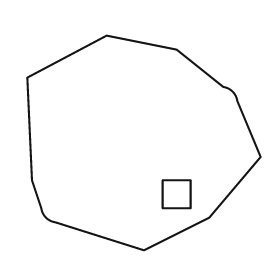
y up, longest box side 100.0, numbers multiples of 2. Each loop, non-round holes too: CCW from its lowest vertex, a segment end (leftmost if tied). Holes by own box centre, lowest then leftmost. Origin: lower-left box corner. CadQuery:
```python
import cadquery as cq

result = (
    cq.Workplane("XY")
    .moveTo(50.0, 0.0)
    .lineTo(78.0, 14.0)
    .lineTo(100.0, 40.0)
    .lineTo(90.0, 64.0)
    .threePointArc((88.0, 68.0), (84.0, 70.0))
    .lineTo(64.0, 86.0)
    .lineTo(34.0, 92.0)
    .lineTo(0.0, 74.0)
    .lineTo(2.0, 30.0)
    .lineTo(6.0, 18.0)
    .threePointArc((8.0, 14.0), (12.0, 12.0))
    .close()
    .moveTo(58.0, 18.0)
    .lineTo(70.0, 18.0)
    .lineTo(70.0, 30.0)
    .lineTo(58.0, 30.0)
    .close()
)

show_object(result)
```